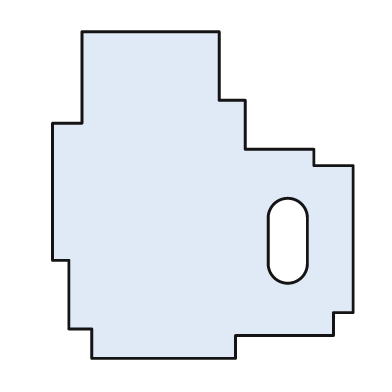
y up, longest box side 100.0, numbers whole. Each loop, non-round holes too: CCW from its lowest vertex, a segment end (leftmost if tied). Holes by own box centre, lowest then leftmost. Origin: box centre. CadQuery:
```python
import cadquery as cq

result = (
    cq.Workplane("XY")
    .moveTo(-34.0, -50.0)
    .lineTo(10.0, -50.0)
    .lineTo(10.0, -43.0)
    .lineTo(40.0, -43.0)
    .lineTo(40.0, -36.0)
    .lineTo(46.0, -36.0)
    .lineTo(46.0, 9.0)
    .lineTo(34.0, 9.0)
    .lineTo(34.0, 14.0)
    .lineTo(13.0, 14.0)
    .lineTo(13.0, 29.0)
    .lineTo(5.0, 29.0)
    .lineTo(5.0, 50.0)
    .lineTo(-37.0, 50.0)
    .lineTo(-37.0, 22.0)
    .lineTo(-46.0, 22.0)
    .lineTo(-46.0, -20.0)
    .lineTo(-41.0, -20.0)
    .lineTo(-41.0, -41.0)
    .lineTo(-34.0, -41.0)
    .close()
    .moveTo(20.0, -21.0)
    .threePointArc((26.0, -27.0), (32.0, -21.0))
    .lineTo(32.0, -7.0)
    .threePointArc((26.0, -1.0), (20.0, -7.0))
    .close()
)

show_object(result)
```